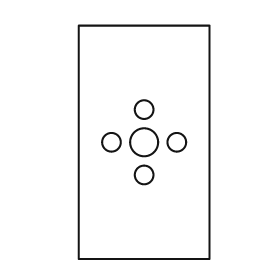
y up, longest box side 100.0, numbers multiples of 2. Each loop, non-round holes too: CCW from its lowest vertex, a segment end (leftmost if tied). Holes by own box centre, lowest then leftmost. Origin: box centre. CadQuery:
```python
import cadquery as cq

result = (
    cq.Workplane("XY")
    .moveTo(-28.0, -50.0)
    .lineTo(28.0, -50.0)
    .lineTo(28.0, 50.0)
    .lineTo(-28.0, 50.0)
    .close()
    .moveTo(0.0, -14.0)
    .circle(4.0)
    .moveTo(-14.0, 0.0)
    .circle(4.0)
    .moveTo(0.0, 0.0)
    .circle(6.0)
    .moveTo(14.0, 0.0)
    .circle(4.0)
    .moveTo(0.0, 14.0)
    .circle(4.0)
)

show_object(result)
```